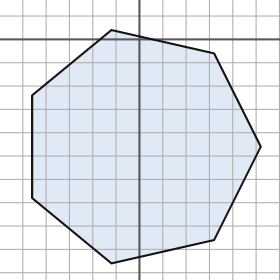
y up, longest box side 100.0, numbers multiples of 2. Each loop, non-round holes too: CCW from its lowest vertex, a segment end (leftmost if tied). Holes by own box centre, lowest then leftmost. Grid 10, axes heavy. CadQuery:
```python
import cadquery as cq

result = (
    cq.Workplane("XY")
    .moveTo(-12.0, -96.0)
    .lineTo(32.0, -86.0)
    .lineTo(52.0, -46.0)
    .lineTo(32.0, -6.0)
    .lineTo(-12.0, 4.0)
    .lineTo(-46.0, -24.0)
    .lineTo(-46.0, -68.0)
    .close()
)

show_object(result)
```